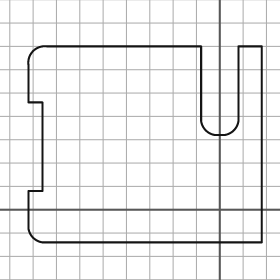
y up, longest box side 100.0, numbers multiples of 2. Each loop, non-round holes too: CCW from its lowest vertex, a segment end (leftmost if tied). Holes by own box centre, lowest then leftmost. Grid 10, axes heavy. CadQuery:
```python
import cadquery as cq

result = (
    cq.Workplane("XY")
    .moveTo(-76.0, -14.0)
    .lineTo(18.0, -14.0)
    .lineTo(18.0, 70.0)
    .lineTo(8.0, 70.0)
    .lineTo(8.0, 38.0)
    .threePointArc((6.0, 34.0), (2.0, 32.0))
    .lineTo(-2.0, 32.0)
    .threePointArc((-6.0, 34.0), (-8.0, 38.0))
    .lineTo(-8.0, 70.0)
    .lineTo(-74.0, 70.0)
    .threePointArc((-80.0, 68.0), (-82.0, 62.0))
    .lineTo(-82.0, 46.0)
    .lineTo(-76.0, 46.0)
    .lineTo(-76.0, 8.0)
    .lineTo(-82.0, 8.0)
    .lineTo(-82.0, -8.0)
    .threePointArc((-80.0, -12.0), (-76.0, -14.0))
    .close()
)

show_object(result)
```